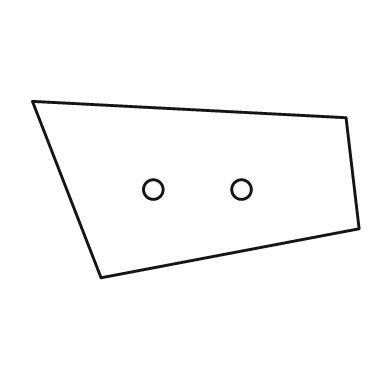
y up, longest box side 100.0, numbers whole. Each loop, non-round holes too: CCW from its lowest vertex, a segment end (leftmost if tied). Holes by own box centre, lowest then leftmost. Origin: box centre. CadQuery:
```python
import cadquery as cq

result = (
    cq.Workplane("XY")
    .moveTo(-29.0, -27.0)
    .lineTo(50.0, -12.0)
    .lineTo(46.0, 22.0)
    .lineTo(-50.0, 27.0)
    .close()
    .moveTo(-13.0, 0.0)
    .circle(3.0)
    .moveTo(14.0, 0.0)
    .circle(3.0)
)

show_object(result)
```